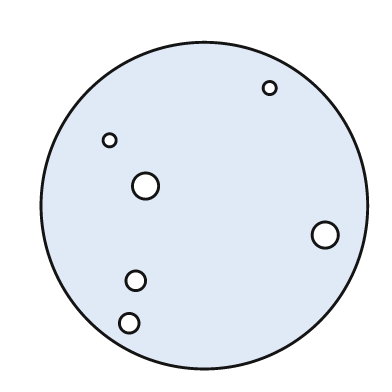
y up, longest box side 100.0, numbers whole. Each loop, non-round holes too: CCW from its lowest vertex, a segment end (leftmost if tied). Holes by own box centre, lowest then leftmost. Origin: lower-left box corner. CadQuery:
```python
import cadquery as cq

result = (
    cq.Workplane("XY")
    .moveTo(50.0, 50.0)
    .circle(50.0)
    .moveTo(27.0, 14.0)
    .circle(3.0)
    .moveTo(29.0, 27.0)
    .circle(3.0)
    .moveTo(87.0, 41.0)
    .circle(4.0)
    .moveTo(32.0, 56.0)
    .circle(4.0)
    .moveTo(21.0, 70.0)
    .circle(2.0)
    .moveTo(70.0, 86.0)
    .circle(2.0)
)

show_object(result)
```